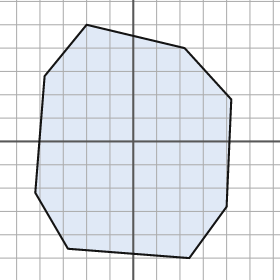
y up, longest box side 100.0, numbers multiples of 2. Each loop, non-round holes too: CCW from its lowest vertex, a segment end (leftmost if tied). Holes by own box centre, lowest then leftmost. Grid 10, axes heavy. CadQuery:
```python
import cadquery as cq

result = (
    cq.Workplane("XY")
    .moveTo(24.0, -50.0)
    .lineTo(40.0, -28.0)
    .lineTo(42.0, 18.0)
    .lineTo(22.0, 40.0)
    .lineTo(-20.0, 50.0)
    .lineTo(-38.0, 28.0)
    .lineTo(-42.0, -22.0)
    .lineTo(-28.0, -46.0)
    .close()
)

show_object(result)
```